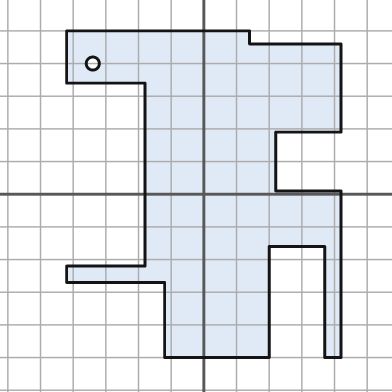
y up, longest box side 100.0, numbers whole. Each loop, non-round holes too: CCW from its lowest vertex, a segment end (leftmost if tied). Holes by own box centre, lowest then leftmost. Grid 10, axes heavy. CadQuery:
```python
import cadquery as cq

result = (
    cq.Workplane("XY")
    .moveTo(-12.0, -50.0)
    .lineTo(20.0, -50.0)
    .lineTo(20.0, -16.0)
    .lineTo(37.0, -16.0)
    .lineTo(37.0, -50.0)
    .lineTo(42.0, -50.0)
    .lineTo(42.0, 1.0)
    .lineTo(22.0, 1.0)
    .lineTo(22.0, 19.0)
    .lineTo(42.0, 19.0)
    .lineTo(42.0, 46.0)
    .lineTo(14.0, 46.0)
    .lineTo(14.0, 50.0)
    .lineTo(-42.0, 50.0)
    .lineTo(-42.0, 34.0)
    .lineTo(-18.0, 34.0)
    .lineTo(-18.0, -22.0)
    .lineTo(-42.0, -22.0)
    .lineTo(-42.0, -27.0)
    .lineTo(-12.0, -27.0)
    .close()
    .moveTo(-34.0, 40.0)
    .circle(2.0)
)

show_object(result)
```